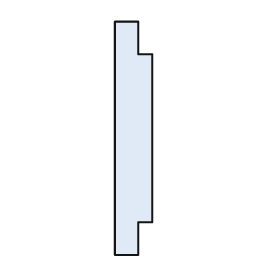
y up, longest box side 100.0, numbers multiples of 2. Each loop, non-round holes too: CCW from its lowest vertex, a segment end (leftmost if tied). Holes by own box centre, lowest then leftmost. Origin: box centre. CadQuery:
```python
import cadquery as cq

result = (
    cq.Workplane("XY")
    .moveTo(-8.0, -50.0)
    .lineTo(2.0, -50.0)
    .lineTo(2.0, -36.0)
    .lineTo(8.0, -36.0)
    .lineTo(8.0, 36.0)
    .lineTo(2.0, 36.0)
    .lineTo(2.0, 50.0)
    .lineTo(-8.0, 50.0)
    .close()
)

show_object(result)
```